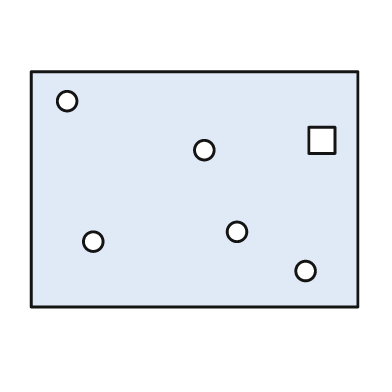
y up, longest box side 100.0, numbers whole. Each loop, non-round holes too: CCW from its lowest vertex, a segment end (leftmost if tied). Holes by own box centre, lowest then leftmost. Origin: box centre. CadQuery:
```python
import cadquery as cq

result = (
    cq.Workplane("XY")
    .moveTo(-50.0, -36.0)
    .lineTo(50.0, -36.0)
    .lineTo(50.0, 36.0)
    .lineTo(-50.0, 36.0)
    .close()
    .moveTo(34.0, -25.0)
    .circle(3.0)
    .moveTo(-31.0, -16.0)
    .circle(3.0)
    .moveTo(13.0, -13.0)
    .circle(3.0)
    .moveTo(3.0, 12.0)
    .circle(3.0)
    .moveTo(35.0, 11.0)
    .lineTo(43.0, 11.0)
    .lineTo(43.0, 19.0)
    .lineTo(35.0, 19.0)
    .close()
    .moveTo(-39.0, 27.0)
    .circle(3.0)
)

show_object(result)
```